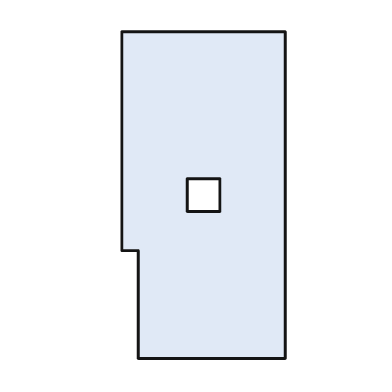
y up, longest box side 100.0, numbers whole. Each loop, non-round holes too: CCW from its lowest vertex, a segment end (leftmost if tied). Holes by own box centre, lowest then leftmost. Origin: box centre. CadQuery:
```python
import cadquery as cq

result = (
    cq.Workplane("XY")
    .moveTo(-20.0, -50.0)
    .lineTo(25.0, -50.0)
    .lineTo(25.0, 50.0)
    .lineTo(-25.0, 50.0)
    .lineTo(-25.0, -17.0)
    .lineTo(-20.0, -17.0)
    .close()
    .moveTo(-5.0, -5.0)
    .lineTo(5.0, -5.0)
    .lineTo(5.0, 5.0)
    .lineTo(-5.0, 5.0)
    .close()
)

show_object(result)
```